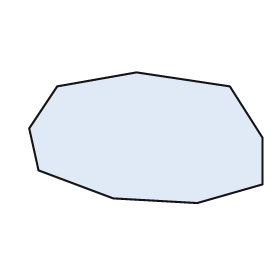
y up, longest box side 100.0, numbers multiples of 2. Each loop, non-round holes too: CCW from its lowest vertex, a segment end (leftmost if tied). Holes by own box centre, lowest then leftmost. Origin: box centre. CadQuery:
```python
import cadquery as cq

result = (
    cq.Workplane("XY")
    .moveTo(22.0, -28.0)
    .lineTo(50.0, -20.0)
    .lineTo(50.0, 0.0)
    .lineTo(36.0, 22.0)
    .lineTo(-4.0, 28.0)
    .lineTo(-38.0, 22.0)
    .lineTo(-50.0, 4.0)
    .lineTo(-46.0, -14.0)
    .lineTo(-14.0, -26.0)
    .close()
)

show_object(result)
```